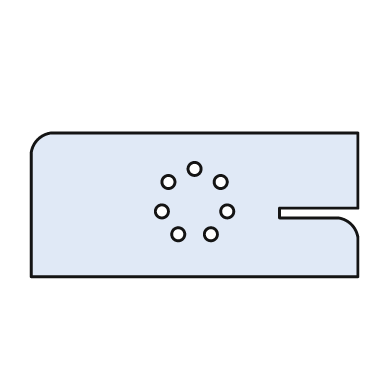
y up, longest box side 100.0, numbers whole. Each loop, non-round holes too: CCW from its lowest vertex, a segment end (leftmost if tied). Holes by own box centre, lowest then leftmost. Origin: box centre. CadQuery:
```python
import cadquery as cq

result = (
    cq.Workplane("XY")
    .moveTo(-50.0, -22.0)
    .lineTo(50.0, -22.0)
    .lineTo(50.0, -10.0)
    .threePointArc((48.0, -6.0), (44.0, -4.0))
    .lineTo(26.0, -4.0)
    .lineTo(26.0, -1.0)
    .lineTo(50.0, -1.0)
    .lineTo(50.0, 22.0)
    .lineTo(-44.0, 22.0)
    .threePointArc((-48.0, 20.0), (-50.0, 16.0))
    .close()
    .moveTo(-5.0, -9.0)
    .circle(2.0)
    .moveTo(5.0, -9.0)
    .circle(2.0)
    .moveTo(-10.0, -2.0)
    .circle(2.0)
    .moveTo(10.0, -2.0)
    .circle(2.0)
    .moveTo(-8.0, 7.0)
    .circle(2.0)
    .moveTo(8.0, 7.0)
    .circle(2.0)
    .moveTo(0.0, 11.0)
    .circle(2.0)
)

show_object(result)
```